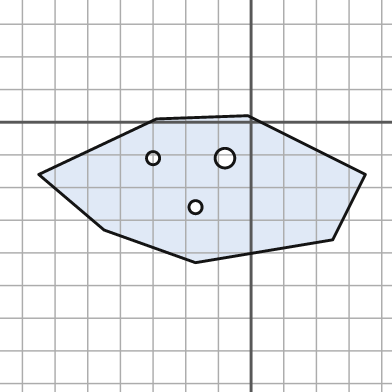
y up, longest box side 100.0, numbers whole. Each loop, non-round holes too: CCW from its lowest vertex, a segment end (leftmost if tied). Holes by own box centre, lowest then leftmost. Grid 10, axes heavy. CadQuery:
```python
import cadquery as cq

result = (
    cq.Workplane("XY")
    .moveTo(-17.0, -43.0)
    .lineTo(25.0, -36.0)
    .lineTo(35.0, -16.0)
    .lineTo(-1.0, 2.0)
    .lineTo(-29.0, 1.0)
    .lineTo(-65.0, -16.0)
    .lineTo(-45.0, -33.0)
    .close()
    .moveTo(-17.0, -26.0)
    .circle(2.0)
    .moveTo(-30.0, -11.0)
    .circle(2.0)
    .moveTo(-8.0, -11.0)
    .circle(3.0)
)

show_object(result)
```